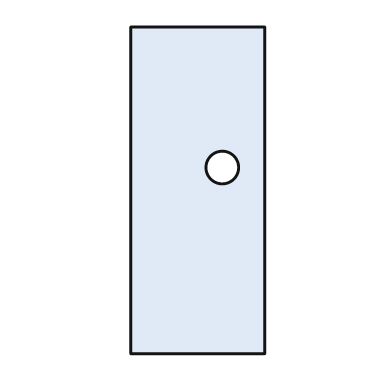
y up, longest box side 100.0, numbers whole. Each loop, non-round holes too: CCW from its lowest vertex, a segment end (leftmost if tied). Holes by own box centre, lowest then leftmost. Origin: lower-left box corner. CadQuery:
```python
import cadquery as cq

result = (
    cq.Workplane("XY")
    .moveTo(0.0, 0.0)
    .lineTo(41.0, 0.0)
    .lineTo(41.0, 100.0)
    .lineTo(0.0, 100.0)
    .close()
    .moveTo(28.0, 57.0)
    .circle(5.0)
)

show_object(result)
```